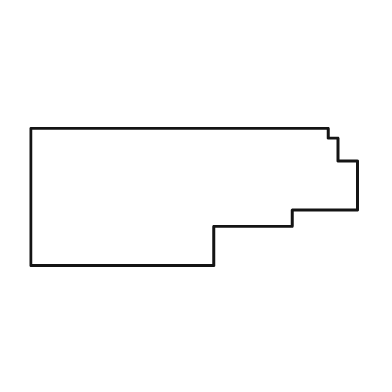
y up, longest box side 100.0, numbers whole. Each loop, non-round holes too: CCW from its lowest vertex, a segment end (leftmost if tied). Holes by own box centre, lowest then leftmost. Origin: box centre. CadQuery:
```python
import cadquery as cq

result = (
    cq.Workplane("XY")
    .moveTo(-50.0, -21.0)
    .lineTo(6.0, -21.0)
    .lineTo(6.0, -9.0)
    .lineTo(30.0, -9.0)
    .lineTo(30.0, -4.0)
    .lineTo(50.0, -4.0)
    .lineTo(50.0, 11.0)
    .lineTo(44.0, 11.0)
    .lineTo(44.0, 18.0)
    .lineTo(41.0, 18.0)
    .lineTo(41.0, 21.0)
    .lineTo(-50.0, 21.0)
    .close()
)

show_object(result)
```